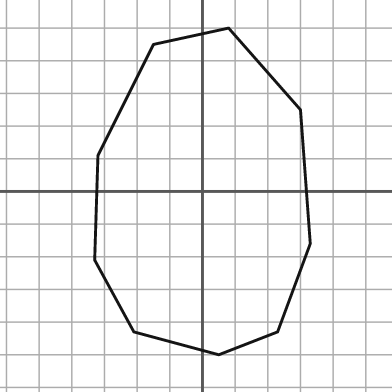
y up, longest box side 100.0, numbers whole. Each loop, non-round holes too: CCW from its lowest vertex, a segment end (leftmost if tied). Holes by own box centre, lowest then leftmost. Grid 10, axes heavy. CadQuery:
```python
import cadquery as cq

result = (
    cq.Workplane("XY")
    .moveTo(5.0, -50.0)
    .lineTo(23.0, -43.0)
    .lineTo(33.0, -16.0)
    .lineTo(30.0, 25.0)
    .lineTo(8.0, 50.0)
    .lineTo(-15.0, 45.0)
    .lineTo(-32.0, 11.0)
    .lineTo(-33.0, -21.0)
    .lineTo(-21.0, -43.0)
    .close()
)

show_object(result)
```